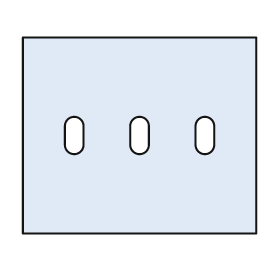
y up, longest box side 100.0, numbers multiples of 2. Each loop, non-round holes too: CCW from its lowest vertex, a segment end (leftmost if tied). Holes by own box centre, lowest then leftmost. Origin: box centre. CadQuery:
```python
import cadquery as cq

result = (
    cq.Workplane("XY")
    .moveTo(-50.0, -42.0)
    .lineTo(50.0, -42.0)
    .lineTo(50.0, 42.0)
    .lineTo(-50.0, 42.0)
    .close()
    .moveTo(-32.0, -4.0)
    .threePointArc((-28.0, -8.0), (-24.0, -4.0))
    .lineTo(-24.0, 4.0)
    .threePointArc((-28.0, 8.0), (-32.0, 4.0))
    .close()
    .moveTo(-4.0, -4.0)
    .threePointArc((0.0, -8.0), (4.0, -4.0))
    .lineTo(4.0, 4.0)
    .threePointArc((0.0, 8.0), (-4.0, 4.0))
    .close()
    .moveTo(24.0, -4.0)
    .threePointArc((28.0, -8.0), (32.0, -4.0))
    .lineTo(32.0, 4.0)
    .threePointArc((28.0, 8.0), (24.0, 4.0))
    .close()
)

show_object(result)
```